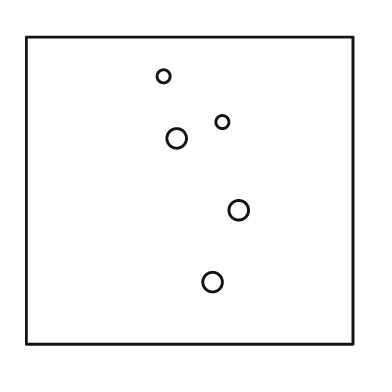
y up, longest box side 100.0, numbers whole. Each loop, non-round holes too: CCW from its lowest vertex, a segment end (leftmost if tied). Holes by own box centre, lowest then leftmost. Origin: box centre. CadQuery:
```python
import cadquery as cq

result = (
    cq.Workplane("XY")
    .moveTo(-50.0, -47.0)
    .lineTo(50.0, -47.0)
    .lineTo(50.0, 47.0)
    .lineTo(-50.0, 47.0)
    .close()
    .moveTo(7.0, -28.0)
    .circle(3.0)
    .moveTo(15.0, -6.0)
    .circle(3.0)
    .moveTo(-4.0, 16.0)
    .circle(3.0)
    .moveTo(10.0, 21.0)
    .circle(2.0)
    .moveTo(-8.0, 35.0)
    .circle(2.0)
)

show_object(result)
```